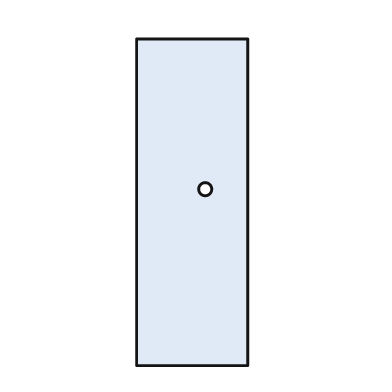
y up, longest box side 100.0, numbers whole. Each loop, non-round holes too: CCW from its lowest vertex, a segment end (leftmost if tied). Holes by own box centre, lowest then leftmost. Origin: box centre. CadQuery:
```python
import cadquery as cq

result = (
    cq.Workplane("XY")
    .moveTo(-17.0, -50.0)
    .lineTo(17.0, -50.0)
    .lineTo(17.0, 50.0)
    .lineTo(-17.0, 50.0)
    .close()
    .moveTo(4.0, 4.0)
    .circle(2.0)
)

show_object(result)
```